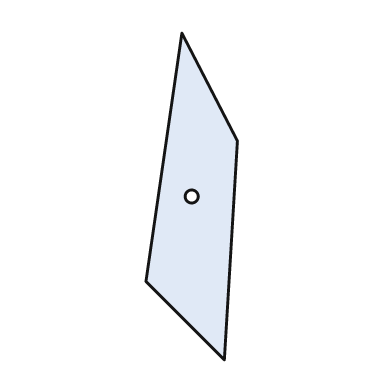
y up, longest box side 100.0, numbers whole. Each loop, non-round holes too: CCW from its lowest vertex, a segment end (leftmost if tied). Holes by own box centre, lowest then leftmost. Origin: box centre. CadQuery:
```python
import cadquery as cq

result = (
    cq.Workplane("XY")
    .moveTo(10.0, -50.0)
    .lineTo(14.0, 17.0)
    .lineTo(-3.0, 50.0)
    .lineTo(-14.0, -26.0)
    .close()
    .moveTo(0.0, 0.0)
    .circle(2.0)
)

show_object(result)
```